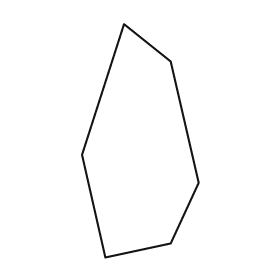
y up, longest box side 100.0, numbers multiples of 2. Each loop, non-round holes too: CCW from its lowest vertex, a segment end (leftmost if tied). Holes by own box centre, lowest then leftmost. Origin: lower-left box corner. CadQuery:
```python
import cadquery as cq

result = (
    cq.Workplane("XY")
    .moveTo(10.0, 0.0)
    .lineTo(38.0, 6.0)
    .lineTo(50.0, 32.0)
    .lineTo(38.0, 84.0)
    .lineTo(18.0, 100.0)
    .lineTo(0.0, 44.0)
    .close()
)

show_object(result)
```